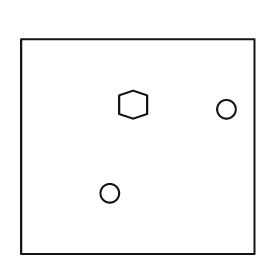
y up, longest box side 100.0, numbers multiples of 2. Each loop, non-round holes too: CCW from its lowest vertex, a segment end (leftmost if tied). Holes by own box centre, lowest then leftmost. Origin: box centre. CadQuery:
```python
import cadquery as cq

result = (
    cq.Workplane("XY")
    .moveTo(-50.0, -46.0)
    .lineTo(50.0, -46.0)
    .lineTo(50.0, 46.0)
    .lineTo(-50.0, 46.0)
    .close()
    .moveTo(-12.0, -20.0)
    .circle(4.0)
    .moveTo(38.0, 16.0)
    .circle(4.0)
    .moveTo(-2.0, 12.0)
    .lineTo(4.0, 14.0)
    .lineTo(4.0, 22.0)
    .lineTo(-2.0, 24.0)
    .lineTo(-8.0, 22.0)
    .lineTo(-8.0, 14.0)
    .close()
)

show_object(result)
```